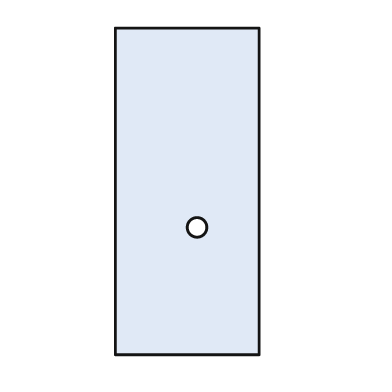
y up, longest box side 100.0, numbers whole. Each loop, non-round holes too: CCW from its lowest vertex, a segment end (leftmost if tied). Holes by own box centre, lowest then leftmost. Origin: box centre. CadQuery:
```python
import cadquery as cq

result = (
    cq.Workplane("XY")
    .moveTo(-22.0, -50.0)
    .lineTo(22.0, -50.0)
    .lineTo(22.0, 50.0)
    .lineTo(-22.0, 50.0)
    .close()
    .moveTo(3.0, -11.0)
    .circle(3.0)
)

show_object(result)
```